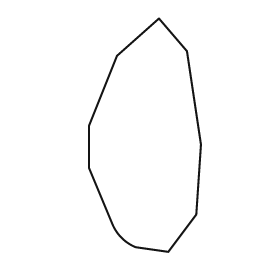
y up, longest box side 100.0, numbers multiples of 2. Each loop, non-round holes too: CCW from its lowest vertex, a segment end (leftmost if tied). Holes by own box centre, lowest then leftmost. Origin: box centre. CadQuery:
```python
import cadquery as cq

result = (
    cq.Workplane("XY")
    .moveTo(10.0, -50.0)
    .lineTo(22.0, -34.0)
    .lineTo(24.0, -4.0)
    .lineTo(18.0, 36.0)
    .lineTo(6.0, 50.0)
    .lineTo(-12.0, 34.0)
    .lineTo(-24.0, 4.0)
    .lineTo(-24.0, -14.0)
    .lineTo(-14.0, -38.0)
    .threePointArc((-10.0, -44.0), (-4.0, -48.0))
    .close()
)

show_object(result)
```